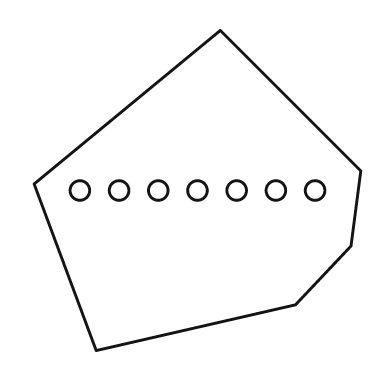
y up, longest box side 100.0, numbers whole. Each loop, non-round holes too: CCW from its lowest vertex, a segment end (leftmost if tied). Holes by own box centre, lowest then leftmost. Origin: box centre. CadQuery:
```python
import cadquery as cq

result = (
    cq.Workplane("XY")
    .moveTo(-31.0, -49.0)
    .lineTo(30.0, -35.0)
    .lineTo(47.0, -17.0)
    .lineTo(50.0, 6.0)
    .lineTo(7.0, 49.0)
    .lineTo(-50.0, 2.0)
    .close()
    .moveTo(-36.0, 0.0)
    .circle(3.0)
    .moveTo(-24.0, 0.0)
    .circle(3.0)
    .moveTo(-12.0, 0.0)
    .circle(3.0)
    .moveTo(0.0, 0.0)
    .circle(3.0)
    .moveTo(12.0, 0.0)
    .circle(3.0)
    .moveTo(24.0, 0.0)
    .circle(3.0)
    .moveTo(36.0, 0.0)
    .circle(3.0)
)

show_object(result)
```